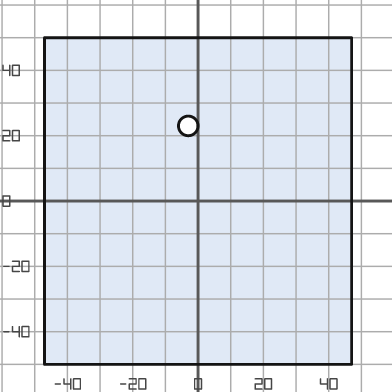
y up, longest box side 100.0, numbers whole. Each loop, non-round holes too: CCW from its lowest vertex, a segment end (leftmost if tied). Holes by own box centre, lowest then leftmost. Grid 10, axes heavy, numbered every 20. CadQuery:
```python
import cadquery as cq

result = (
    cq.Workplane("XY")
    .moveTo(-47.0, -50.0)
    .lineTo(47.0, -50.0)
    .lineTo(47.0, 50.0)
    .lineTo(-47.0, 50.0)
    .close()
    .moveTo(-3.0, 23.0)
    .circle(3.0)
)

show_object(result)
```